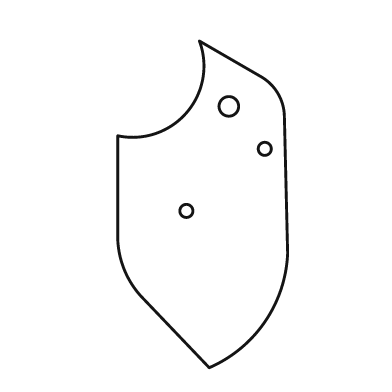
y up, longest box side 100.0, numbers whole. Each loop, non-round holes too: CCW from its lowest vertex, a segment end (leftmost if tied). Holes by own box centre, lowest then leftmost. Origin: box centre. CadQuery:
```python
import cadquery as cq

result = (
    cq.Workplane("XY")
    .moveTo(2.0, -50.0)
    .threePointArc((19.0, -36.0), (26.0, -15.0))
    .lineTo(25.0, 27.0)
    .threePointArc((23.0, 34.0), (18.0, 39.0))
    .lineTo(-1.0, 50.0)
    .threePointArc((-5.0, 28.0), (-26.0, 21.0))
    .lineTo(-26.0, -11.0)
    .threePointArc((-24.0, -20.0), (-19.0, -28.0))
    .close()
    .moveTo(-5.0, -2.0)
    .circle(2.0)
    .moveTo(19.0, 17.0)
    .circle(2.0)
    .moveTo(8.0, 30.0)
    .circle(3.0)
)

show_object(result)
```